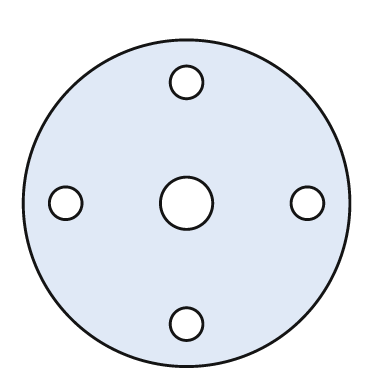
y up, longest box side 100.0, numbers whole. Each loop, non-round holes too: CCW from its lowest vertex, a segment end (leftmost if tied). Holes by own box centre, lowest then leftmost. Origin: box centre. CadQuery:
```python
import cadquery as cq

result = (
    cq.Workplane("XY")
    .moveTo(0.0, 0.0)
    .circle(50.0)
    .moveTo(0.0, -37.0)
    .circle(5.0)
    .moveTo(-37.0, 0.0)
    .circle(5.0)
    .moveTo(0.0, 0.0)
    .circle(8.0)
    .moveTo(37.0, 0.0)
    .circle(5.0)
    .moveTo(0.0, 37.0)
    .circle(5.0)
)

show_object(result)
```